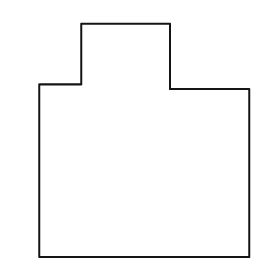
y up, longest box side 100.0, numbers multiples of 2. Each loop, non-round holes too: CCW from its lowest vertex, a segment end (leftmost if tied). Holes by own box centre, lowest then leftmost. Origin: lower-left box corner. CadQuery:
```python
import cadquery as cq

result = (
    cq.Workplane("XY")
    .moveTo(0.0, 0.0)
    .lineTo(90.0, 0.0)
    .lineTo(90.0, 72.0)
    .lineTo(56.0, 72.0)
    .lineTo(56.0, 100.0)
    .lineTo(18.0, 100.0)
    .lineTo(18.0, 74.0)
    .lineTo(0.0, 74.0)
    .close()
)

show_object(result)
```